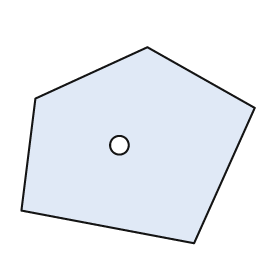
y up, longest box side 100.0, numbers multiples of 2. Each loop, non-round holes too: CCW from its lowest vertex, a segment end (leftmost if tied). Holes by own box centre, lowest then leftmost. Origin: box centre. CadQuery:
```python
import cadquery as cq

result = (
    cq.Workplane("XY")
    .moveTo(24.0, -42.0)
    .lineTo(50.0, 16.0)
    .lineTo(4.0, 42.0)
    .lineTo(-44.0, 20.0)
    .lineTo(-50.0, -28.0)
    .close()
    .moveTo(-8.0, 0.0)
    .circle(4.0)
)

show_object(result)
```